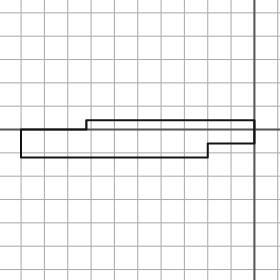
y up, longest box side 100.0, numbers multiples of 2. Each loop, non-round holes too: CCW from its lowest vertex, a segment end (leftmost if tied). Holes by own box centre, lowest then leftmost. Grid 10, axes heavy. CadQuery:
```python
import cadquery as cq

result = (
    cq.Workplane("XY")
    .moveTo(-100.0, -12.0)
    .lineTo(-20.0, -12.0)
    .lineTo(-20.0, -6.0)
    .lineTo(0.0, -6.0)
    .lineTo(0.0, 4.0)
    .lineTo(-72.0, 4.0)
    .lineTo(-72.0, 0.0)
    .lineTo(-100.0, 0.0)
    .close()
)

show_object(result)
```